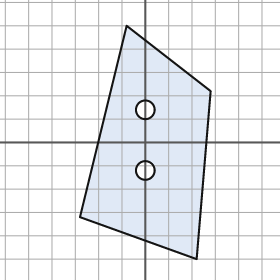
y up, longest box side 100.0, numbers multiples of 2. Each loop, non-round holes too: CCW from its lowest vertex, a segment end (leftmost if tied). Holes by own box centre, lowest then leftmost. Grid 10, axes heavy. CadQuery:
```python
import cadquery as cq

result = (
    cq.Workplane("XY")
    .moveTo(22.0, -50.0)
    .lineTo(28.0, 22.0)
    .lineTo(-8.0, 50.0)
    .lineTo(-28.0, -32.0)
    .close()
    .moveTo(0.0, -12.0)
    .circle(4.0)
    .moveTo(0.0, 14.0)
    .circle(4.0)
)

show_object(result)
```